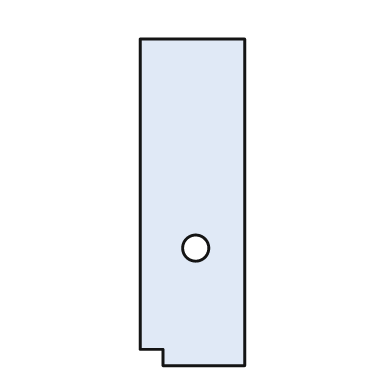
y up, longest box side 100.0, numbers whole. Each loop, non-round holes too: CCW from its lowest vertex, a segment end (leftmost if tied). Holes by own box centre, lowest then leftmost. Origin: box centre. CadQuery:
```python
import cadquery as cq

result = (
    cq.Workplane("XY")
    .moveTo(-9.0, -50.0)
    .lineTo(16.0, -50.0)
    .lineTo(16.0, 50.0)
    .lineTo(-16.0, 50.0)
    .lineTo(-16.0, -45.0)
    .lineTo(-9.0, -45.0)
    .close()
    .moveTo(1.0, -14.0)
    .circle(4.0)
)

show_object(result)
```